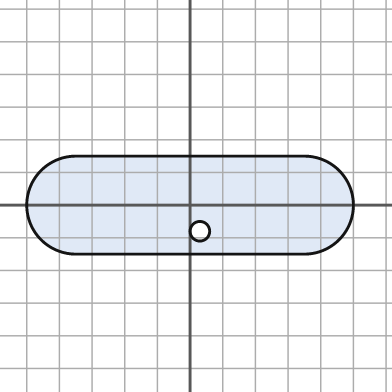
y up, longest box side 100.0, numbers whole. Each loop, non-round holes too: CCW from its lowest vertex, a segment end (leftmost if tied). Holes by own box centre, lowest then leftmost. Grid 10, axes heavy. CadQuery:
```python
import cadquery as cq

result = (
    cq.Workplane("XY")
    .moveTo(-35.0, -15.0)
    .lineTo(35.0, -15.0)
    .threePointArc((50.0, 0.0), (35.0, 15.0))
    .lineTo(-35.0, 15.0)
    .threePointArc((-50.0, 0.0), (-35.0, -15.0))
    .close()
    .moveTo(3.0, -8.0)
    .circle(3.0)
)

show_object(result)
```